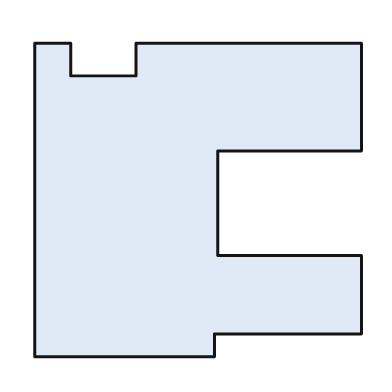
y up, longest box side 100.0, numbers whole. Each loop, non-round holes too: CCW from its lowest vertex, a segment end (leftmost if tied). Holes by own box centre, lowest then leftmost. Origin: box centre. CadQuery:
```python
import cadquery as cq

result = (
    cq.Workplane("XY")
    .moveTo(-50.0, -48.0)
    .lineTo(5.0, -48.0)
    .lineTo(5.0, -41.0)
    .lineTo(50.0, -41.0)
    .lineTo(50.0, -17.0)
    .lineTo(6.0, -17.0)
    .lineTo(6.0, 15.0)
    .lineTo(50.0, 15.0)
    .lineTo(50.0, 48.0)
    .lineTo(-19.0, 48.0)
    .lineTo(-19.0, 38.0)
    .lineTo(-39.0, 38.0)
    .lineTo(-39.0, 48.0)
    .lineTo(-50.0, 48.0)
    .close()
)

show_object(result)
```